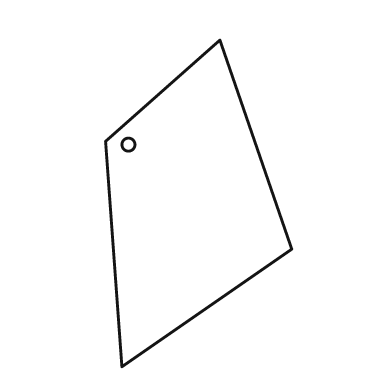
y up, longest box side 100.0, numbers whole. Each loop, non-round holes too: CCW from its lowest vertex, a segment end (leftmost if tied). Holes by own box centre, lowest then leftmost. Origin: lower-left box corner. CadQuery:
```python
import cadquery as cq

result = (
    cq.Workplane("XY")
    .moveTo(5.0, 0.0)
    .lineTo(57.0, 36.0)
    .lineTo(35.0, 100.0)
    .lineTo(0.0, 69.0)
    .close()
    .moveTo(7.0, 68.0)
    .circle(2.0)
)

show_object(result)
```